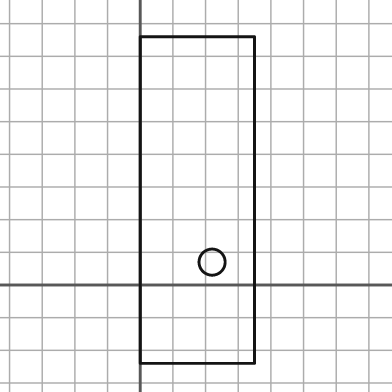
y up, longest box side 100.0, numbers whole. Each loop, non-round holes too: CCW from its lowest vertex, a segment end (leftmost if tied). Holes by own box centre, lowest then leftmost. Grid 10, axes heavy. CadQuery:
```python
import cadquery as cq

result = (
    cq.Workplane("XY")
    .moveTo(0.0, -24.0)
    .lineTo(35.0, -24.0)
    .lineTo(35.0, 76.0)
    .lineTo(0.0, 76.0)
    .close()
    .moveTo(22.0, 7.0)
    .circle(4.0)
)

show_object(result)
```